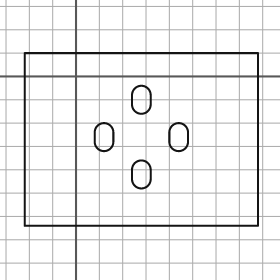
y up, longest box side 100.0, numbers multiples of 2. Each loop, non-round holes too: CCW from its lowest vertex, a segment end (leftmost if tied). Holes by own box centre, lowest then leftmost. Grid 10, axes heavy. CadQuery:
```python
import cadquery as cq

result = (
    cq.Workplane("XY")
    .moveTo(-22.0, -64.0)
    .lineTo(78.0, -64.0)
    .lineTo(78.0, 10.0)
    .lineTo(-22.0, 10.0)
    .close()
    .moveTo(24.0, -44.0)
    .threePointArc((28.0, -48.0), (32.0, -44.0))
    .lineTo(32.0, -40.0)
    .threePointArc((28.0, -36.0), (24.0, -40.0))
    .close()
    .moveTo(8.0, -28.0)
    .threePointArc((12.0, -32.0), (16.0, -28.0))
    .lineTo(16.0, -24.0)
    .threePointArc((12.0, -20.0), (8.0, -24.0))
    .close()
    .moveTo(40.0, -28.0)
    .threePointArc((44.0, -32.0), (48.0, -28.0))
    .lineTo(48.0, -24.0)
    .threePointArc((44.0, -20.0), (40.0, -24.0))
    .close()
    .moveTo(24.0, -12.0)
    .threePointArc((28.0, -16.0), (32.0, -12.0))
    .lineTo(32.0, -8.0)
    .threePointArc((28.0, -4.0), (24.0, -8.0))
    .close()
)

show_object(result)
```